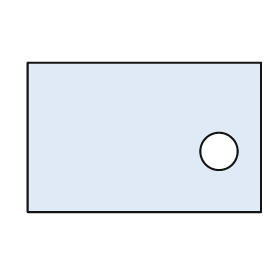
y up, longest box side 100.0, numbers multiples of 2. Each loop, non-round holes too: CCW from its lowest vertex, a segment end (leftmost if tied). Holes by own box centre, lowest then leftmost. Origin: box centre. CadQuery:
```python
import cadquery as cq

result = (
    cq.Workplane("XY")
    .moveTo(-50.0, -32.0)
    .lineTo(50.0, -32.0)
    .lineTo(50.0, 32.0)
    .lineTo(-50.0, 32.0)
    .close()
    .moveTo(32.0, -6.0)
    .circle(8.0)
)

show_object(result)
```